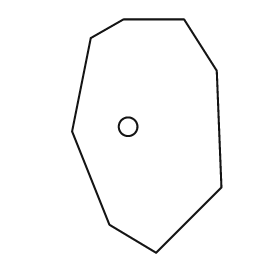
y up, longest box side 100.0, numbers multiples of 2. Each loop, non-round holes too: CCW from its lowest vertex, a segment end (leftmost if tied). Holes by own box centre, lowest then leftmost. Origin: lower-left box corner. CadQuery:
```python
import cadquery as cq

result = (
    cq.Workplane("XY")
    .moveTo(36.0, 0.0)
    .lineTo(64.0, 28.0)
    .lineTo(62.0, 78.0)
    .lineTo(48.0, 100.0)
    .lineTo(22.0, 100.0)
    .lineTo(8.0, 92.0)
    .lineTo(0.0, 52.0)
    .lineTo(16.0, 12.0)
    .close()
    .moveTo(24.0, 54.0)
    .circle(4.0)
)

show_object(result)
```